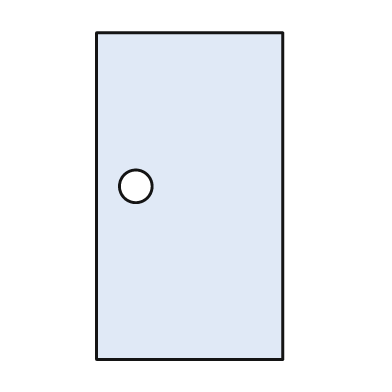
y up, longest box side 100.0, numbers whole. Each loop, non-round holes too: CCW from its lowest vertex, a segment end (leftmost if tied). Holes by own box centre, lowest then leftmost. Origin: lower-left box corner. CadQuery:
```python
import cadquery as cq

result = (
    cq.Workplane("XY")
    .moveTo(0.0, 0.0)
    .lineTo(57.0, 0.0)
    .lineTo(57.0, 100.0)
    .lineTo(0.0, 100.0)
    .close()
    .moveTo(12.0, 53.0)
    .circle(5.0)
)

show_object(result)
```